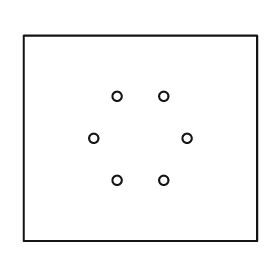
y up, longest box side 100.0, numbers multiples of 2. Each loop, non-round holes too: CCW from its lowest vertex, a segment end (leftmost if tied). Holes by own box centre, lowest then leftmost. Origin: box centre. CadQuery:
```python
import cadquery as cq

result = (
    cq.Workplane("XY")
    .moveTo(-50.0, -44.0)
    .lineTo(50.0, -44.0)
    .lineTo(50.0, 44.0)
    .lineTo(-50.0, 44.0)
    .close()
    .moveTo(-10.0, -18.0)
    .circle(2.0)
    .moveTo(10.0, -18.0)
    .circle(2.0)
    .moveTo(-20.0, 0.0)
    .circle(2.0)
    .moveTo(20.0, 0.0)
    .circle(2.0)
    .moveTo(-10.0, 18.0)
    .circle(2.0)
    .moveTo(10.0, 18.0)
    .circle(2.0)
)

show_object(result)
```